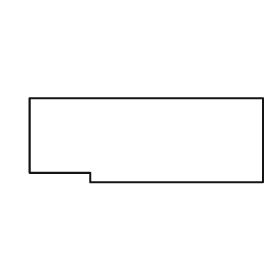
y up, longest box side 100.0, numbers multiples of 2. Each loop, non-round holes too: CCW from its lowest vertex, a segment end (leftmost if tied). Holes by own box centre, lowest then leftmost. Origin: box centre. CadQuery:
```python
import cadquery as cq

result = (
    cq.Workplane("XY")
    .moveTo(-24.0, -18.0)
    .lineTo(50.0, -18.0)
    .lineTo(50.0, 18.0)
    .lineTo(-50.0, 18.0)
    .lineTo(-50.0, -14.0)
    .lineTo(-24.0, -14.0)
    .close()
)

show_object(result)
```